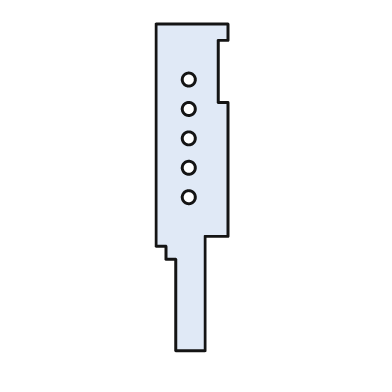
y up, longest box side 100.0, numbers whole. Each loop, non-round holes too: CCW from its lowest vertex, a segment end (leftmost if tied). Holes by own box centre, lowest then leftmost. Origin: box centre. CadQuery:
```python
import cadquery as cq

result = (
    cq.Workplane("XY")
    .moveTo(-5.0, -50.0)
    .lineTo(4.0, -50.0)
    .lineTo(4.0, -15.0)
    .lineTo(11.0, -15.0)
    .lineTo(11.0, 26.0)
    .lineTo(8.0, 26.0)
    .lineTo(8.0, 45.0)
    .lineTo(11.0, 45.0)
    .lineTo(11.0, 50.0)
    .lineTo(-11.0, 50.0)
    .lineTo(-11.0, -18.0)
    .lineTo(-8.0, -18.0)
    .lineTo(-8.0, -22.0)
    .lineTo(-5.0, -22.0)
    .close()
    .moveTo(-1.0, -3.0)
    .circle(2.0)
    .moveTo(-1.0, 6.0)
    .circle(2.0)
    .moveTo(-1.0, 15.0)
    .circle(2.0)
    .moveTo(-1.0, 24.0)
    .circle(2.0)
    .moveTo(-1.0, 33.0)
    .circle(2.0)
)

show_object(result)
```